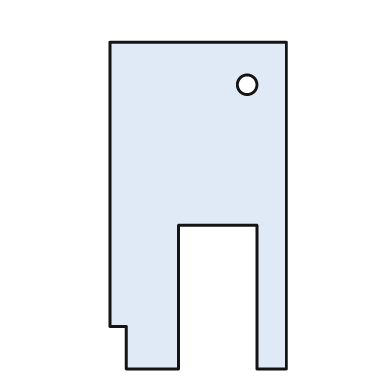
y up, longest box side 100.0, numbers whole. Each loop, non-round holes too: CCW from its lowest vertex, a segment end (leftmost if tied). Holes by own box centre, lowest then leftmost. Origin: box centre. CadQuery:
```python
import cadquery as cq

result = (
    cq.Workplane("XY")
    .moveTo(-22.0, -50.0)
    .lineTo(-6.0, -50.0)
    .lineTo(-6.0, -6.0)
    .lineTo(18.0, -6.0)
    .lineTo(18.0, -50.0)
    .lineTo(27.0, -50.0)
    .lineTo(27.0, 50.0)
    .lineTo(-27.0, 50.0)
    .lineTo(-27.0, -37.0)
    .lineTo(-22.0, -37.0)
    .close()
    .moveTo(15.0, 37.0)
    .circle(3.0)
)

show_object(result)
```